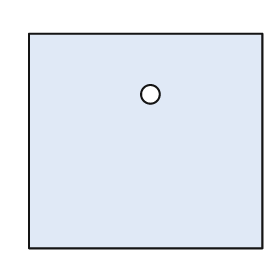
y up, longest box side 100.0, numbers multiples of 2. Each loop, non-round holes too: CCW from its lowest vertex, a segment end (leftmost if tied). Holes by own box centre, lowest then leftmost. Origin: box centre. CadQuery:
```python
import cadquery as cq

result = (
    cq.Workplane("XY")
    .moveTo(-50.0, -46.0)
    .lineTo(50.0, -46.0)
    .lineTo(50.0, 46.0)
    .lineTo(-50.0, 46.0)
    .close()
    .moveTo(2.0, 20.0)
    .circle(4.0)
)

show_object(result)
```